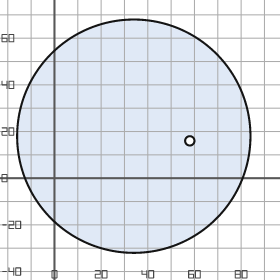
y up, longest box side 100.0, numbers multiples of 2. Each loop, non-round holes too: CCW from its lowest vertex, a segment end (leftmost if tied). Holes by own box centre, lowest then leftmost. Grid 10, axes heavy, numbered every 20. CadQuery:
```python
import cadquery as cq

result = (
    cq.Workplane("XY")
    .moveTo(34.0, 18.0)
    .circle(50.0)
    .moveTo(58.0, 16.0)
    .circle(2.0)
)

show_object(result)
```